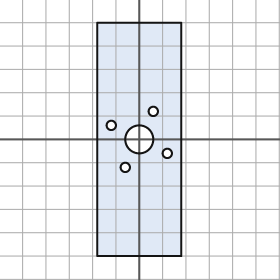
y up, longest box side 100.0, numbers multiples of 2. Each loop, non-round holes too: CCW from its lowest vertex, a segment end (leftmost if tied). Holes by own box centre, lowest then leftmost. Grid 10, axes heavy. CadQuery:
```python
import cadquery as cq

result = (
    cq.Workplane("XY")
    .moveTo(-18.0, -50.0)
    .lineTo(18.0, -50.0)
    .lineTo(18.0, 50.0)
    .lineTo(-18.0, 50.0)
    .close()
    .moveTo(-6.0, -12.0)
    .circle(2.0)
    .moveTo(12.0, -6.0)
    .circle(2.0)
    .moveTo(0.0, 0.0)
    .circle(6.0)
    .moveTo(-12.0, 6.0)
    .circle(2.0)
    .moveTo(6.0, 12.0)
    .circle(2.0)
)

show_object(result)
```